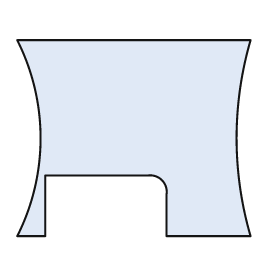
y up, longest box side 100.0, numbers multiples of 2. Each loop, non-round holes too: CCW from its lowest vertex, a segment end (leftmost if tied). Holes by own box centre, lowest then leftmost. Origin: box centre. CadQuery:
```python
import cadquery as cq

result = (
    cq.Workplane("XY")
    .moveTo(-50.0, -42.0)
    .lineTo(-38.0, -42.0)
    .lineTo(-38.0, -16.0)
    .lineTo(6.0, -16.0)
    .threePointArc((12.0, -18.0), (14.0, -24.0))
    .lineTo(14.0, -42.0)
    .lineTo(50.0, -42.0)
    .threePointArc((44.0, 0.0), (50.0, 42.0))
    .lineTo(-50.0, 42.0)
    .threePointArc((-40.0, 0.0), (-50.0, -42.0))
    .close()
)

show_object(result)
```